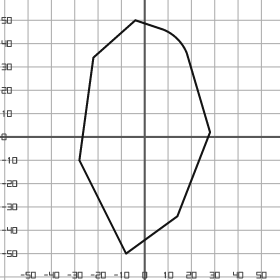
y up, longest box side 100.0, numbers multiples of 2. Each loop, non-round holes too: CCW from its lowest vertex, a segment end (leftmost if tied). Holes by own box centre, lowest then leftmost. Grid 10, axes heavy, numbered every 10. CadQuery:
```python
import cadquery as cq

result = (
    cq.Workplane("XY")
    .moveTo(-8.0, -50.0)
    .lineTo(14.0, -34.0)
    .lineTo(28.0, 2.0)
    .lineTo(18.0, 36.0)
    .threePointArc((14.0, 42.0), (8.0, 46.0))
    .lineTo(-4.0, 50.0)
    .lineTo(-22.0, 34.0)
    .lineTo(-28.0, -10.0)
    .close()
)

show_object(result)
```